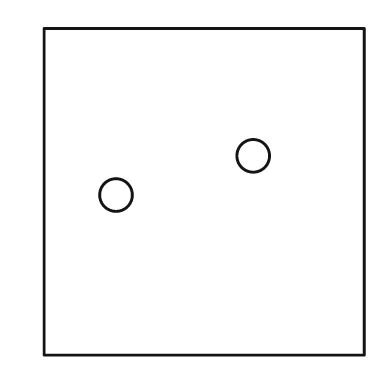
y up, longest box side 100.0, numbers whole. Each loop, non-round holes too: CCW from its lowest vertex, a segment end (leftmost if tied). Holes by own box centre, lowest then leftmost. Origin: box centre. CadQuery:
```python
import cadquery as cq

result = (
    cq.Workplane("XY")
    .moveTo(-49.0, -50.0)
    .lineTo(49.0, -50.0)
    .lineTo(49.0, 50.0)
    .lineTo(-49.0, 50.0)
    .close()
    .moveTo(-27.0, -1.0)
    .circle(5.0)
    .moveTo(15.0, 11.0)
    .circle(5.0)
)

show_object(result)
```